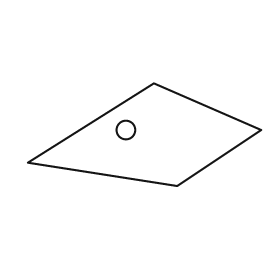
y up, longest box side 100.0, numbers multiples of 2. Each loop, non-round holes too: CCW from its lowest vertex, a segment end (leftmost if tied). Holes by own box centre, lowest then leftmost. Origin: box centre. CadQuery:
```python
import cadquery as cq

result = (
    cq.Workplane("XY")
    .moveTo(14.0, -22.0)
    .lineTo(50.0, 2.0)
    .lineTo(4.0, 22.0)
    .lineTo(-50.0, -12.0)
    .close()
    .moveTo(-8.0, 2.0)
    .circle(4.0)
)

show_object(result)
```